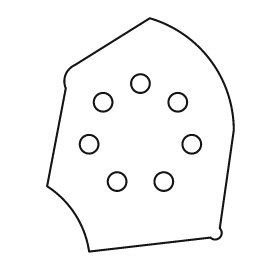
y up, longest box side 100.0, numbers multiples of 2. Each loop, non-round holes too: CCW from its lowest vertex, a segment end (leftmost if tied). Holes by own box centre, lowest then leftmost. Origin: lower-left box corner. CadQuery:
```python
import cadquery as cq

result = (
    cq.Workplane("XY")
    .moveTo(18.0, 0.0)
    .lineTo(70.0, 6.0)
    .threePointArc((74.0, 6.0), (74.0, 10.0))
    .lineTo(80.0, 52.0)
    .threePointArc((70.0, 82.0), (44.0, 100.0))
    .lineTo(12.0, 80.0)
    .threePointArc((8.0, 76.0), (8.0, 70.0))
    .lineTo(0.0, 28.0)
    .threePointArc((12.0, 16.0), (18.0, 0.0))
    .close()
    .moveTo(30.0, 30.0)
    .circle(4.0)
    .moveTo(50.0, 30.0)
    .circle(4.0)
    .moveTo(18.0, 46.0)
    .circle(4.0)
    .moveTo(62.0, 46.0)
    .circle(4.0)
    .moveTo(24.0, 64.0)
    .circle(4.0)
    .moveTo(56.0, 64.0)
    .circle(4.0)
    .moveTo(40.0, 72.0)
    .circle(4.0)
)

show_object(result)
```